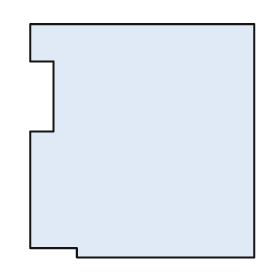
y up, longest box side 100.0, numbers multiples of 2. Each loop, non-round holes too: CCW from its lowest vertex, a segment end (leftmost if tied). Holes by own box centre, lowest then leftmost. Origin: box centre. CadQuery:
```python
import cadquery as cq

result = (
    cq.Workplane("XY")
    .moveTo(-28.0, -50.0)
    .lineTo(48.0, -50.0)
    .lineTo(48.0, 50.0)
    .lineTo(-48.0, 50.0)
    .lineTo(-48.0, 34.0)
    .lineTo(-38.0, 34.0)
    .lineTo(-38.0, 4.0)
    .lineTo(-48.0, 4.0)
    .lineTo(-48.0, -46.0)
    .lineTo(-28.0, -46.0)
    .close()
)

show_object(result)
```